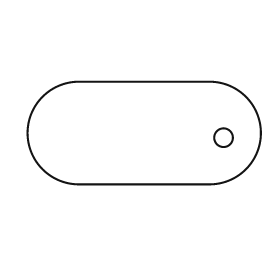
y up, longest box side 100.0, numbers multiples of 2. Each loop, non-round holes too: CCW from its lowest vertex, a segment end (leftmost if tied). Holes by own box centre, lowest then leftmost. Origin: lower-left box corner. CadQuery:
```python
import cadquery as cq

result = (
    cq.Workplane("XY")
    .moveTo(22.0, 0.0)
    .lineTo(78.0, 0.0)
    .threePointArc((100.0, 22.0), (78.0, 44.0))
    .lineTo(22.0, 44.0)
    .threePointArc((0.0, 22.0), (22.0, 0.0))
    .close()
    .moveTo(84.0, 20.0)
    .circle(4.0)
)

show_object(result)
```